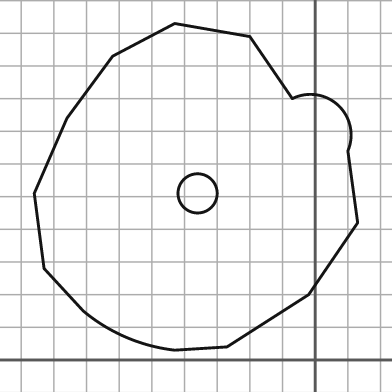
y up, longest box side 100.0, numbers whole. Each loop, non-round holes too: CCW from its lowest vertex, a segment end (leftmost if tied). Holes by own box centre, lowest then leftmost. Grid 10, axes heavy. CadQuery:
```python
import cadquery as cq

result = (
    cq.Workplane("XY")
    .moveTo(-43.0, 3.0)
    .lineTo(-27.0, 4.0)
    .lineTo(-2.0, 20.0)
    .lineTo(13.0, 42.0)
    .lineTo(10.0, 64.0)
    .threePointArc((7.0, 78.0), (-7.0, 80.0))
    .lineTo(-20.0, 99.0)
    .lineTo(-43.0, 103.0)
    .lineTo(-62.0, 93.0)
    .lineTo(-76.0, 74.0)
    .lineTo(-86.0, 51.0)
    .lineTo(-83.0, 28.0)
    .lineTo(-71.0, 15.0)
    .threePointArc((-58.0, 7.0), (-43.0, 3.0))
    .close()
    .moveTo(-36.0, 51.0)
    .circle(6.0)
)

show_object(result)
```